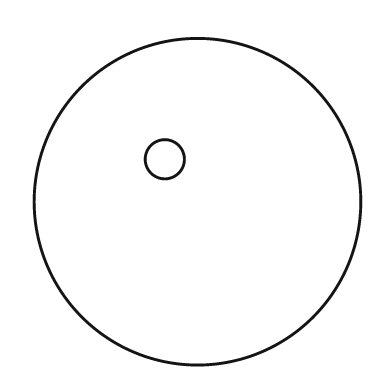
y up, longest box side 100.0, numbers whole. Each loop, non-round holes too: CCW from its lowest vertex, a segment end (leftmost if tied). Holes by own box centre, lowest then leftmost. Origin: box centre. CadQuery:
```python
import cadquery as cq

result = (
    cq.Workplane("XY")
    .moveTo(0.0, 0.0)
    .circle(50.0)
    .moveTo(-10.0, 13.0)
    .circle(6.0)
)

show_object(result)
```